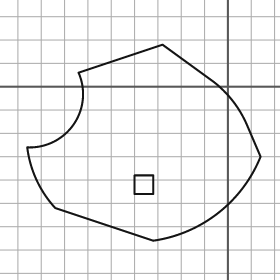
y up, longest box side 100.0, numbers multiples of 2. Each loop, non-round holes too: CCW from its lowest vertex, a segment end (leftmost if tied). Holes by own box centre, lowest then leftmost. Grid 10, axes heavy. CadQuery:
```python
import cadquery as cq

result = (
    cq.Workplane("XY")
    .moveTo(-32.0, -66.0)
    .threePointArc((-4.0, -54.0), (14.0, -30.0))
    .lineTo(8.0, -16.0)
    .threePointArc((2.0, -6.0), (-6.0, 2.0))
    .lineTo(-28.0, 18.0)
    .lineTo(-64.0, 6.0)
    .threePointArc((-66.0, -16.0), (-86.0, -26.0))
    .threePointArc((-82.0, -40.0), (-74.0, -52.0))
    .close()
    .moveTo(-40.0, -46.0)
    .lineTo(-32.0, -46.0)
    .lineTo(-32.0, -38.0)
    .lineTo(-40.0, -38.0)
    .close()
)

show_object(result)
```